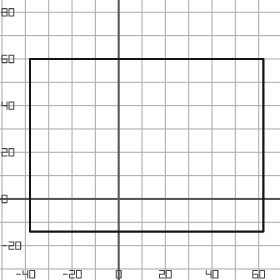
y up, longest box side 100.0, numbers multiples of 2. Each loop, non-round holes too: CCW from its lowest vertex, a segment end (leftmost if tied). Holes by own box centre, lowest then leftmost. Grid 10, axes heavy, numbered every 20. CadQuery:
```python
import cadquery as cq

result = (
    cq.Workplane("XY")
    .moveTo(-38.0, -14.0)
    .lineTo(62.0, -14.0)
    .lineTo(62.0, 60.0)
    .lineTo(-38.0, 60.0)
    .close()
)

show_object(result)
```